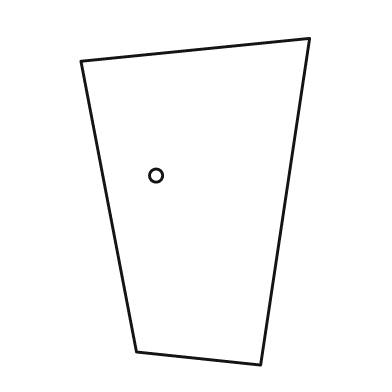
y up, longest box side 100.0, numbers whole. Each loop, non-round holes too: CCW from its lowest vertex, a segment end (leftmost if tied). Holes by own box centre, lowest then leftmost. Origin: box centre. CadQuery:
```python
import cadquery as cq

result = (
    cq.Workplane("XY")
    .moveTo(20.0, -50.0)
    .lineTo(35.0, 50.0)
    .lineTo(-35.0, 43.0)
    .lineTo(-18.0, -46.0)
    .close()
    .moveTo(-12.0, 8.0)
    .circle(2.0)
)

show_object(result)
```